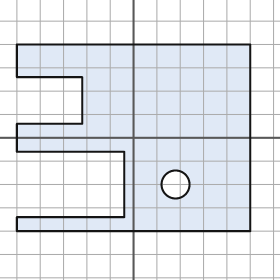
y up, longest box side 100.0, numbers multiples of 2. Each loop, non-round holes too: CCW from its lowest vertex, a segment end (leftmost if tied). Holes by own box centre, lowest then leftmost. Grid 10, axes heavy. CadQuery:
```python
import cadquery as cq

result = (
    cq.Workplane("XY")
    .moveTo(-50.0, -40.0)
    .lineTo(50.0, -40.0)
    .lineTo(50.0, 40.0)
    .lineTo(-50.0, 40.0)
    .lineTo(-50.0, 26.0)
    .lineTo(-22.0, 26.0)
    .lineTo(-22.0, 6.0)
    .lineTo(-50.0, 6.0)
    .lineTo(-50.0, -6.0)
    .lineTo(-4.0, -6.0)
    .lineTo(-4.0, -34.0)
    .lineTo(-50.0, -34.0)
    .close()
    .moveTo(18.0, -20.0)
    .circle(6.0)
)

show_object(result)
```